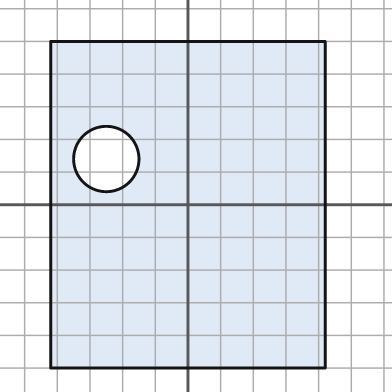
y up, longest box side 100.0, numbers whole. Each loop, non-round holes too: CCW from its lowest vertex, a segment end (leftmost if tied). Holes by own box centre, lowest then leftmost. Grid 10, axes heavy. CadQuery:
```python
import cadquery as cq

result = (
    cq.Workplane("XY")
    .moveTo(-42.0, -50.0)
    .lineTo(42.0, -50.0)
    .lineTo(42.0, 50.0)
    .lineTo(-42.0, 50.0)
    .close()
    .moveTo(-25.0, 14.0)
    .circle(10.0)
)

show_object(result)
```